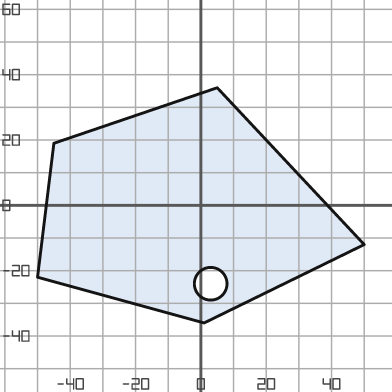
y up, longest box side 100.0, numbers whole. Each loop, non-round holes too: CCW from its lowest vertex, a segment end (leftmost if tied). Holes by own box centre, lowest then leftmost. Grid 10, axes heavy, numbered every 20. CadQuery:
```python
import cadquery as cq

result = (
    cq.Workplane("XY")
    .moveTo(1.0, -36.0)
    .lineTo(50.0, -12.0)
    .lineTo(5.0, 36.0)
    .lineTo(-45.0, 19.0)
    .lineTo(-50.0, -22.0)
    .close()
    .moveTo(3.0, -24.0)
    .circle(5.0)
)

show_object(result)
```